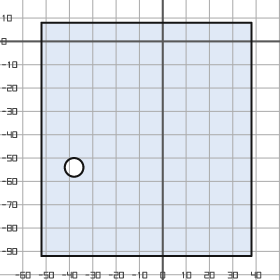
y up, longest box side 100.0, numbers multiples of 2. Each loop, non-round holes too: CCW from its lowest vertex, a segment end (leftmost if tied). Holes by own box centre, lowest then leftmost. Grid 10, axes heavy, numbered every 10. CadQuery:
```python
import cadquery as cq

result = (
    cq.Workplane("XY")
    .moveTo(-52.0, -92.0)
    .lineTo(38.0, -92.0)
    .lineTo(38.0, 8.0)
    .lineTo(-52.0, 8.0)
    .close()
    .moveTo(-38.0, -54.0)
    .circle(4.0)
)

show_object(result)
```